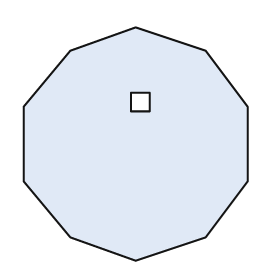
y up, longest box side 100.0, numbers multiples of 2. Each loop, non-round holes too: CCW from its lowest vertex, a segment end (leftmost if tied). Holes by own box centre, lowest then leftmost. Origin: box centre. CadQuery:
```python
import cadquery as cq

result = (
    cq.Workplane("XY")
    .moveTo(0.0, -50.0)
    .lineTo(30.0, -40.0)
    .lineTo(48.0, -16.0)
    .lineTo(48.0, 16.0)
    .lineTo(30.0, 40.0)
    .lineTo(0.0, 50.0)
    .lineTo(-28.0, 40.0)
    .lineTo(-48.0, 16.0)
    .lineTo(-48.0, -16.0)
    .lineTo(-28.0, -40.0)
    .close()
    .moveTo(-2.0, 14.0)
    .lineTo(6.0, 14.0)
    .lineTo(6.0, 22.0)
    .lineTo(-2.0, 22.0)
    .close()
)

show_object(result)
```